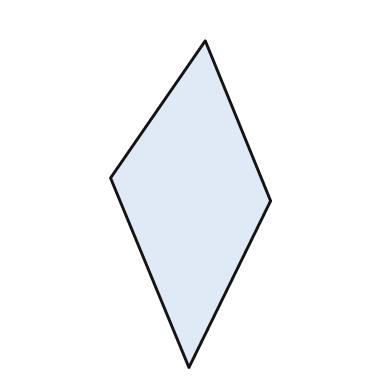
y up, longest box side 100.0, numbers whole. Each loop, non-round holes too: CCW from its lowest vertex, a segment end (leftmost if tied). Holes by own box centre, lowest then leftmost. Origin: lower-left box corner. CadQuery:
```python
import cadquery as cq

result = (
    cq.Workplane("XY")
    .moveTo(24.0, 0.0)
    .lineTo(49.0, 51.0)
    .lineTo(29.0, 100.0)
    .lineTo(0.0, 58.0)
    .close()
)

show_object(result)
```